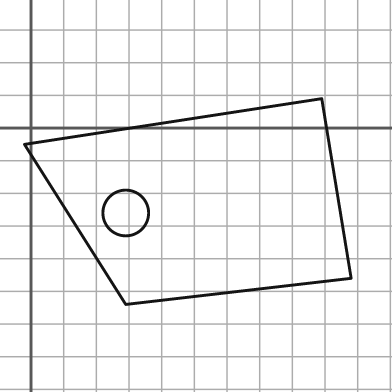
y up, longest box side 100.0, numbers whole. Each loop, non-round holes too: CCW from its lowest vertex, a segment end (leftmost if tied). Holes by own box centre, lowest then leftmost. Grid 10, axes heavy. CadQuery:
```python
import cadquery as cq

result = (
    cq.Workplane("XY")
    .moveTo(29.0, -54.0)
    .lineTo(98.0, -46.0)
    .lineTo(89.0, 9.0)
    .lineTo(-2.0, -5.0)
    .close()
    .moveTo(29.0, -26.0)
    .circle(7.0)
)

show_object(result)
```